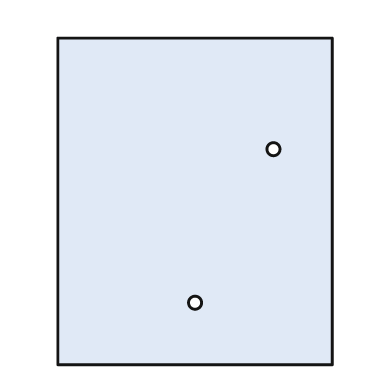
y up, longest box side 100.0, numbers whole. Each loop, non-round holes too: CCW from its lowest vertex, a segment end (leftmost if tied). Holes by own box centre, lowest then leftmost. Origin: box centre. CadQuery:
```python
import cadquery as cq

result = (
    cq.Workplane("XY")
    .moveTo(-42.0, -50.0)
    .lineTo(42.0, -50.0)
    .lineTo(42.0, 50.0)
    .lineTo(-42.0, 50.0)
    .close()
    .moveTo(0.0, -31.0)
    .circle(2.0)
    .moveTo(24.0, 16.0)
    .circle(2.0)
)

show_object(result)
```